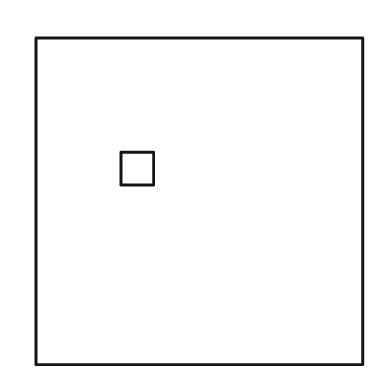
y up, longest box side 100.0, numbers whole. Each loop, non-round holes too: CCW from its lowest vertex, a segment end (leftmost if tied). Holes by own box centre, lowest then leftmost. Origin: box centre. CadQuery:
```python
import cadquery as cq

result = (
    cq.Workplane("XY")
    .moveTo(-50.0, -50.0)
    .lineTo(50.0, -50.0)
    .lineTo(50.0, 50.0)
    .lineTo(-50.0, 50.0)
    .close()
    .moveTo(-24.0, 5.0)
    .lineTo(-14.0, 5.0)
    .lineTo(-14.0, 15.0)
    .lineTo(-24.0, 15.0)
    .close()
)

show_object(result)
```